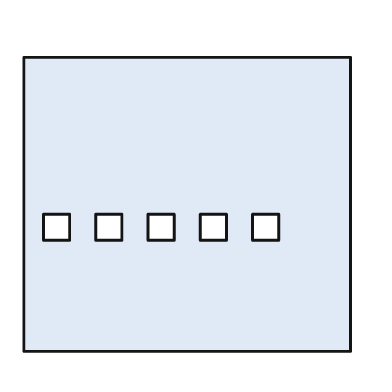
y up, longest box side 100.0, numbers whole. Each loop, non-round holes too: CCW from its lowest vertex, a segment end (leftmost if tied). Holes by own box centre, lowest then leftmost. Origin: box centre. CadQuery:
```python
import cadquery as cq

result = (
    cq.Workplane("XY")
    .moveTo(-50.0, -45.0)
    .lineTo(50.0, -45.0)
    .lineTo(50.0, 45.0)
    .lineTo(-50.0, 45.0)
    .close()
    .moveTo(-44.0, -11.0)
    .lineTo(-36.0, -11.0)
    .lineTo(-36.0, -3.0)
    .lineTo(-44.0, -3.0)
    .close()
    .moveTo(-28.0, -11.0)
    .lineTo(-20.0, -11.0)
    .lineTo(-20.0, -3.0)
    .lineTo(-28.0, -3.0)
    .close()
    .moveTo(-12.0, -11.0)
    .lineTo(-4.0, -11.0)
    .lineTo(-4.0, -3.0)
    .lineTo(-12.0, -3.0)
    .close()
    .moveTo(4.0, -11.0)
    .lineTo(12.0, -11.0)
    .lineTo(12.0, -3.0)
    .lineTo(4.0, -3.0)
    .close()
    .moveTo(20.0, -11.0)
    .lineTo(28.0, -11.0)
    .lineTo(28.0, -3.0)
    .lineTo(20.0, -3.0)
    .close()
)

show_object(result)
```